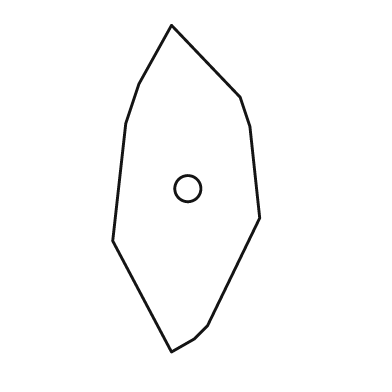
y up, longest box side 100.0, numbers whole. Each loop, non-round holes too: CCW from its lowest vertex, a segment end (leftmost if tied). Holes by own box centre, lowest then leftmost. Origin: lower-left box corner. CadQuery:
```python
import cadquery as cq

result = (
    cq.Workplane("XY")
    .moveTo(18.0, 0.0)
    .lineTo(25.0, 4.0)
    .lineTo(29.0, 8.0)
    .lineTo(45.0, 41.0)
    .lineTo(42.0, 69.0)
    .lineTo(39.0, 78.0)
    .lineTo(18.0, 100.0)
    .lineTo(8.0, 82.0)
    .lineTo(4.0, 70.0)
    .lineTo(0.0, 34.0)
    .close()
    .moveTo(23.0, 50.0)
    .circle(4.0)
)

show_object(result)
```